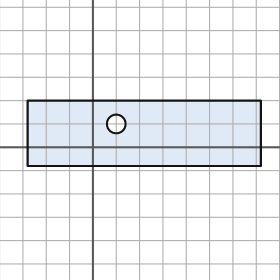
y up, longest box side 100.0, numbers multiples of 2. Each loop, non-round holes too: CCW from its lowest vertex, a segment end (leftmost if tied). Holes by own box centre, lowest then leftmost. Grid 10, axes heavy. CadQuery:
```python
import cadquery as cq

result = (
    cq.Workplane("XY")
    .moveTo(-28.0, -8.0)
    .lineTo(72.0, -8.0)
    .lineTo(72.0, 20.0)
    .lineTo(-28.0, 20.0)
    .close()
    .moveTo(10.0, 10.0)
    .circle(4.0)
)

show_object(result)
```